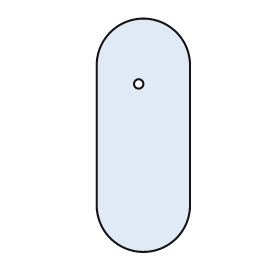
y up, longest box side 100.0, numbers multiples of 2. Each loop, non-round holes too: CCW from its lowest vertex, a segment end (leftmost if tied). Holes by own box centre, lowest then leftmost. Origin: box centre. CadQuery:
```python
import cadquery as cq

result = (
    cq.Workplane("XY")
    .moveTo(-20.0, -30.0)
    .threePointArc((0.0, -50.0), (20.0, -30.0))
    .lineTo(20.0, 30.0)
    .threePointArc((0.0, 50.0), (-20.0, 30.0))
    .close()
    .moveTo(-2.0, 22.0)
    .circle(2.0)
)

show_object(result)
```